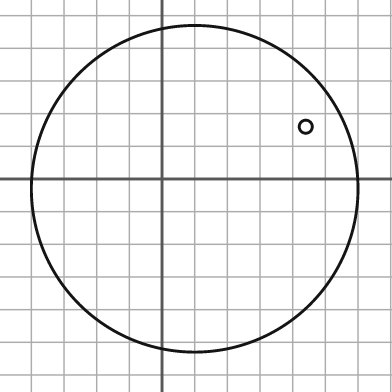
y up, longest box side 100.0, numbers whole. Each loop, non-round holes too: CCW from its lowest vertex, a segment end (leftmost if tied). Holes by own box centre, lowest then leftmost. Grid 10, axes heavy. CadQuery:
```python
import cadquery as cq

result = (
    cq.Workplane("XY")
    .moveTo(10.0, -3.0)
    .circle(50.0)
    .moveTo(44.0, 16.0)
    .circle(2.0)
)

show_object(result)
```